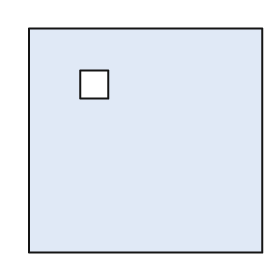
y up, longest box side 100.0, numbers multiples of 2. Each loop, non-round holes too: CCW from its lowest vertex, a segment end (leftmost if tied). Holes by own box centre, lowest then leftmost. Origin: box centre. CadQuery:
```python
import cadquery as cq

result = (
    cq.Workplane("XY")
    .moveTo(-50.0, -48.0)
    .lineTo(50.0, -48.0)
    .lineTo(50.0, 48.0)
    .lineTo(-50.0, 48.0)
    .close()
    .moveTo(-28.0, 18.0)
    .lineTo(-16.0, 18.0)
    .lineTo(-16.0, 30.0)
    .lineTo(-28.0, 30.0)
    .close()
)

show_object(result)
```